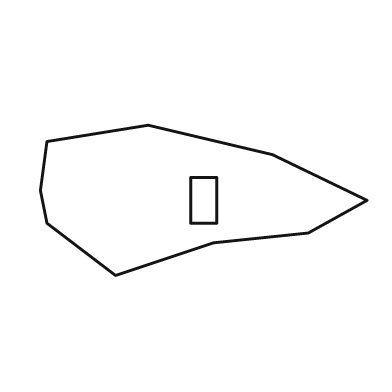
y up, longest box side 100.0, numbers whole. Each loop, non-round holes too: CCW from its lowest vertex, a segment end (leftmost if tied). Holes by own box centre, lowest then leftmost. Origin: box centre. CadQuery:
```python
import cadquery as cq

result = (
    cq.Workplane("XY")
    .moveTo(-27.0, -23.0)
    .lineTo(3.0, -13.0)
    .lineTo(32.0, -10.0)
    .lineTo(50.0, 0.0)
    .lineTo(21.0, 14.0)
    .lineTo(-17.0, 23.0)
    .lineTo(-48.0, 18.0)
    .lineTo(-50.0, 3.0)
    .lineTo(-48.0, -7.0)
    .close()
    .moveTo(-4.0, -7.0)
    .lineTo(4.0, -7.0)
    .lineTo(4.0, 7.0)
    .lineTo(-4.0, 7.0)
    .close()
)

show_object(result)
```